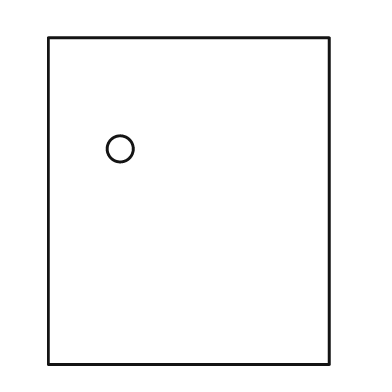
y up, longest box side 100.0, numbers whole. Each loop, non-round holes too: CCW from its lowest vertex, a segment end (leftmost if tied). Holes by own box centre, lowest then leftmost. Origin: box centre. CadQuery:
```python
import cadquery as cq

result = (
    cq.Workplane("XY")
    .moveTo(-43.0, -50.0)
    .lineTo(43.0, -50.0)
    .lineTo(43.0, 50.0)
    .lineTo(-43.0, 50.0)
    .close()
    .moveTo(-21.0, 16.0)
    .circle(4.0)
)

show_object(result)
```